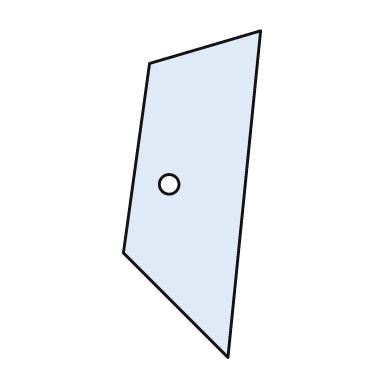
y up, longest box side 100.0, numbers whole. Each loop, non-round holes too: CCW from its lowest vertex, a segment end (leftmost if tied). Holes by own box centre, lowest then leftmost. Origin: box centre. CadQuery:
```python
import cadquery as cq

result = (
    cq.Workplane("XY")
    .moveTo(11.0, -50.0)
    .lineTo(21.0, 50.0)
    .lineTo(-13.0, 40.0)
    .lineTo(-21.0, -18.0)
    .close()
    .moveTo(-7.0, 3.0)
    .circle(3.0)
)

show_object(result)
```